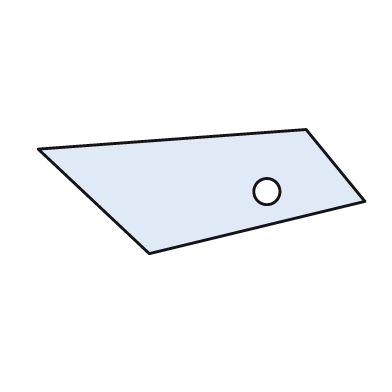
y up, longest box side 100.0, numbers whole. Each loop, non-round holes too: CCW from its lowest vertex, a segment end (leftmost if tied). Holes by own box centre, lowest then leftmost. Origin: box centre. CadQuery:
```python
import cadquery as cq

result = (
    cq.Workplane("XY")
    .moveTo(-16.0, -19.0)
    .lineTo(50.0, -3.0)
    .lineTo(32.0, 19.0)
    .lineTo(-50.0, 13.0)
    .close()
    .moveTo(20.0, 0.0)
    .circle(4.0)
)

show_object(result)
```